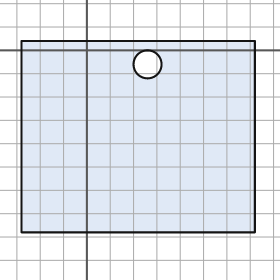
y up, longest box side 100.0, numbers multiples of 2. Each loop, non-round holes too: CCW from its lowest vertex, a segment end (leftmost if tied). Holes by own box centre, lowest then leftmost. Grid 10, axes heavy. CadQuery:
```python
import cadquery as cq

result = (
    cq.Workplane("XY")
    .moveTo(-28.0, -78.0)
    .lineTo(72.0, -78.0)
    .lineTo(72.0, 4.0)
    .lineTo(-28.0, 4.0)
    .close()
    .moveTo(26.0, -6.0)
    .circle(6.0)
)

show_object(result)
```